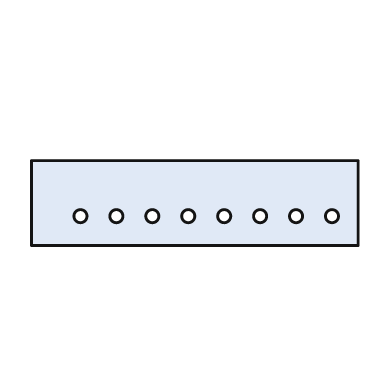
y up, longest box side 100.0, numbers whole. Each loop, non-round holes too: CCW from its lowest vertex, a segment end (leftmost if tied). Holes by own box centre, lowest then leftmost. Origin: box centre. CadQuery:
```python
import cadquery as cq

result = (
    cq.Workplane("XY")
    .moveTo(-50.0, -13.0)
    .lineTo(50.0, -13.0)
    .lineTo(50.0, 13.0)
    .lineTo(-50.0, 13.0)
    .close()
    .moveTo(-35.0, -4.0)
    .circle(2.0)
    .moveTo(-24.0, -4.0)
    .circle(2.0)
    .moveTo(-13.0, -4.0)
    .circle(2.0)
    .moveTo(-2.0, -4.0)
    .circle(2.0)
    .moveTo(9.0, -4.0)
    .circle(2.0)
    .moveTo(20.0, -4.0)
    .circle(2.0)
    .moveTo(31.0, -4.0)
    .circle(2.0)
    .moveTo(42.0, -4.0)
    .circle(2.0)
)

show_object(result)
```